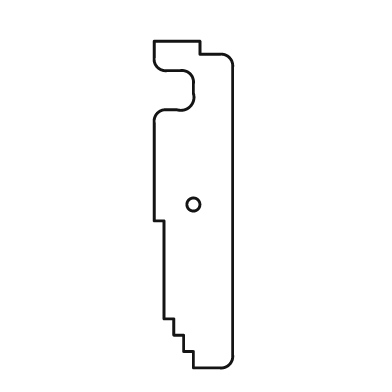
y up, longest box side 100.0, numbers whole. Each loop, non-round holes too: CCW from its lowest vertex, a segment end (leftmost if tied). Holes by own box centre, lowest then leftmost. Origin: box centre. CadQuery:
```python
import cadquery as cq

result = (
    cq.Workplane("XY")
    .moveTo(0.0, -50.0)
    .lineTo(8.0, -50.0)
    .threePointArc((11.0, -49.0), (12.0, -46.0))
    .lineTo(12.0, 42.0)
    .threePointArc((11.0, 45.0), (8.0, 46.0))
    .lineTo(2.0, 46.0)
    .lineTo(2.0, 50.0)
    .lineTo(-12.0, 50.0)
    .lineTo(-12.0, 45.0)
    .threePointArc((-11.0, 42.0), (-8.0, 41.0))
    .lineTo(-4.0, 41.0)
    .threePointArc((-1.0, 40.0), (0.0, 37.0))
    .lineTo(0.0, 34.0)
    .threePointArc((-1.0, 30.0), (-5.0, 29.0))
    .lineTo(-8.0, 29.0)
    .threePointArc((-11.0, 28.0), (-12.0, 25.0))
    .lineTo(-12.0, -5.0)
    .lineTo(-9.0, -5.0)
    .lineTo(-9.0, -35.0)
    .lineTo(-6.0, -35.0)
    .lineTo(-6.0, -40.0)
    .lineTo(-3.0, -40.0)
    .lineTo(-3.0, -45.0)
    .lineTo(0.0, -45.0)
    .close()
    .moveTo(0.0, 0.0)
    .circle(2.0)
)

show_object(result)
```